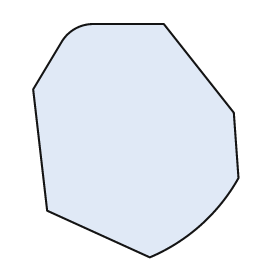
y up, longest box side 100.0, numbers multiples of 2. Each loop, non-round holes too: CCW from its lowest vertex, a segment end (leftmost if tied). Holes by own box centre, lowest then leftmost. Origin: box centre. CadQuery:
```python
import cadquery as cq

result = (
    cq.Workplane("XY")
    .moveTo(6.0, -50.0)
    .threePointArc((28.0, -36.0), (44.0, -16.0))
    .lineTo(42.0, 12.0)
    .lineTo(12.0, 50.0)
    .lineTo(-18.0, 50.0)
    .threePointArc((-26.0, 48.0), (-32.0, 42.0))
    .lineTo(-44.0, 22.0)
    .lineTo(-38.0, -30.0)
    .close()
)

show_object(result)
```